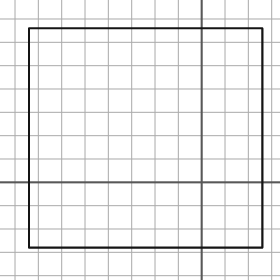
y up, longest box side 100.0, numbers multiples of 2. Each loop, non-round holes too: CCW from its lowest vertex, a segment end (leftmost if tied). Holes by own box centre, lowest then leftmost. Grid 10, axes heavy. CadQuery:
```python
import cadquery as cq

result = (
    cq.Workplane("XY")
    .moveTo(-74.0, -28.0)
    .lineTo(26.0, -28.0)
    .lineTo(26.0, 66.0)
    .lineTo(-74.0, 66.0)
    .close()
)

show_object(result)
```